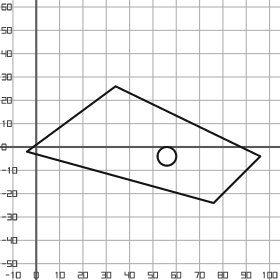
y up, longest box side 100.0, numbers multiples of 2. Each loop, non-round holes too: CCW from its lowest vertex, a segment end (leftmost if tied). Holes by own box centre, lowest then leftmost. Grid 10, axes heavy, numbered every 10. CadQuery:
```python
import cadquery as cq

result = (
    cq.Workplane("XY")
    .moveTo(76.0, -24.0)
    .lineTo(96.0, -4.0)
    .lineTo(34.0, 26.0)
    .lineTo(-4.0, -2.0)
    .close()
    .moveTo(56.0, -4.0)
    .circle(4.0)
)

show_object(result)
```